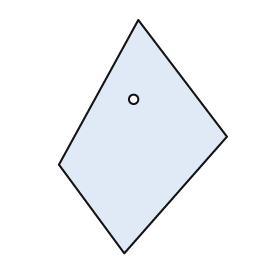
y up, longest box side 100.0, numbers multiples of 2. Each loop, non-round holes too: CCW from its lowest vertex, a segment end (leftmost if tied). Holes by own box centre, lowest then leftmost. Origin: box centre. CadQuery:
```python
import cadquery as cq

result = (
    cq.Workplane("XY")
    .moveTo(-8.0, -50.0)
    .lineTo(36.0, 0.0)
    .lineTo(-2.0, 50.0)
    .lineTo(-36.0, -12.0)
    .close()
    .moveTo(-4.0, 16.0)
    .circle(2.0)
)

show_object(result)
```